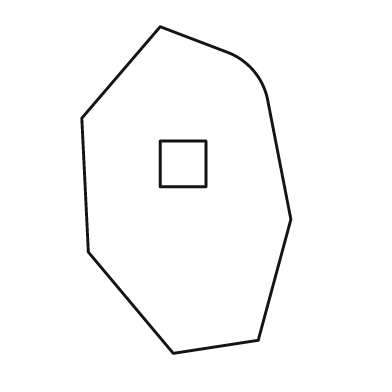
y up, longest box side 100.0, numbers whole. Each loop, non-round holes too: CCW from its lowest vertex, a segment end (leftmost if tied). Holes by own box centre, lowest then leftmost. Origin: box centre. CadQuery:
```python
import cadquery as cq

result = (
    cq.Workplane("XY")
    .moveTo(-4.0, -50.0)
    .lineTo(22.0, -46.0)
    .lineTo(32.0, -9.0)
    .lineTo(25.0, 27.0)
    .threePointArc((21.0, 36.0), (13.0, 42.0))
    .lineTo(-8.0, 50.0)
    .lineTo(-32.0, 22.0)
    .lineTo(-30.0, -19.0)
    .close()
    .moveTo(-8.0, 1.0)
    .lineTo(6.0, 1.0)
    .lineTo(6.0, 15.0)
    .lineTo(-8.0, 15.0)
    .close()
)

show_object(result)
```